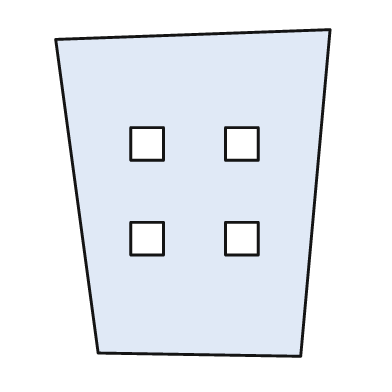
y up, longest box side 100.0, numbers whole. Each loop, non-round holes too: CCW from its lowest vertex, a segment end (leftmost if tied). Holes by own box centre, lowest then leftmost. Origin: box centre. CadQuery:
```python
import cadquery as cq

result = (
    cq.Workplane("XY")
    .moveTo(33.0, -50.0)
    .lineTo(42.0, 50.0)
    .lineTo(-42.0, 47.0)
    .lineTo(-29.0, -49.0)
    .close()
    .moveTo(-19.0, -19.0)
    .lineTo(-9.0, -19.0)
    .lineTo(-9.0, -9.0)
    .lineTo(-19.0, -9.0)
    .close()
    .moveTo(10.0, -19.0)
    .lineTo(20.0, -19.0)
    .lineTo(20.0, -9.0)
    .lineTo(10.0, -9.0)
    .close()
    .moveTo(-19.0, 10.0)
    .lineTo(-9.0, 10.0)
    .lineTo(-9.0, 20.0)
    .lineTo(-19.0, 20.0)
    .close()
    .moveTo(10.0, 10.0)
    .lineTo(20.0, 10.0)
    .lineTo(20.0, 20.0)
    .lineTo(10.0, 20.0)
    .close()
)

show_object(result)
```